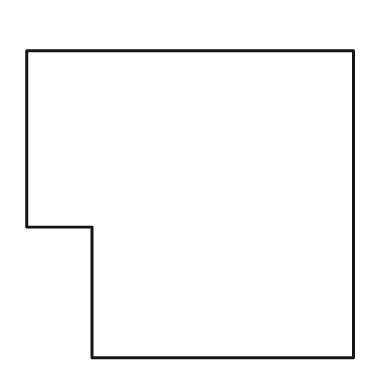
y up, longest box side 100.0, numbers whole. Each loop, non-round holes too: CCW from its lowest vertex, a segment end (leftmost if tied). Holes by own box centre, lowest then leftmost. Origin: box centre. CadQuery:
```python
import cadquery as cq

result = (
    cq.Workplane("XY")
    .moveTo(-30.0, -47.0)
    .lineTo(50.0, -47.0)
    .lineTo(50.0, 47.0)
    .lineTo(-50.0, 47.0)
    .lineTo(-50.0, -7.0)
    .lineTo(-30.0, -7.0)
    .close()
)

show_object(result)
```